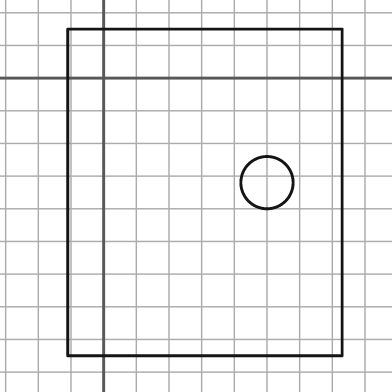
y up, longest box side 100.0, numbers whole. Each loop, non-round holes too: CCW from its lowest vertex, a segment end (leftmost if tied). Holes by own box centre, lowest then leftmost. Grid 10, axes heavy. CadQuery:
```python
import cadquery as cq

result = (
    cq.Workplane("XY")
    .moveTo(-11.0, -85.0)
    .lineTo(73.0, -85.0)
    .lineTo(73.0, 15.0)
    .lineTo(-11.0, 15.0)
    .close()
    .moveTo(50.0, -32.0)
    .circle(8.0)
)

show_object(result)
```